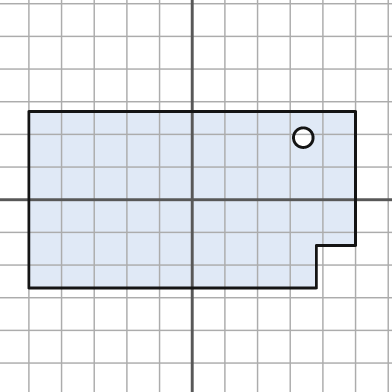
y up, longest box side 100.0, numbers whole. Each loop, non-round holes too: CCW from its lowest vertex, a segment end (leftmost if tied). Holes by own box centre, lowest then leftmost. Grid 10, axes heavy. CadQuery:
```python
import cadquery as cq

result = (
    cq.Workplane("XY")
    .moveTo(-50.0, -27.0)
    .lineTo(38.0, -27.0)
    .lineTo(38.0, -14.0)
    .lineTo(50.0, -14.0)
    .lineTo(50.0, 27.0)
    .lineTo(-50.0, 27.0)
    .close()
    .moveTo(34.0, 19.0)
    .circle(3.0)
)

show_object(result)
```